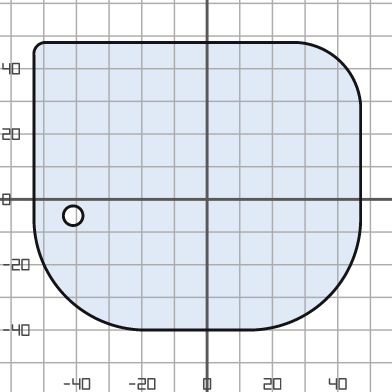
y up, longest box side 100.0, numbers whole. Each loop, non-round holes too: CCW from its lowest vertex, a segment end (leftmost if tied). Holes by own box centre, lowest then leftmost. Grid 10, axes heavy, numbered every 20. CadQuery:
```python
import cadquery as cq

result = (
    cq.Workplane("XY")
    .moveTo(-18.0, -40.0)
    .lineTo(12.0, -40.0)
    .threePointArc((37.0, -30.0), (47.0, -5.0))
    .lineTo(47.0, 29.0)
    .threePointArc((41.0, 42.0), (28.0, 48.0))
    .lineTo(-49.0, 48.0)
    .threePointArc((-52.0, 47.0), (-53.0, 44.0))
    .lineTo(-53.0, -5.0)
    .threePointArc((-43.0, -30.0), (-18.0, -40.0))
    .close()
    .moveTo(-41.0, -5.0)
    .circle(3.0)
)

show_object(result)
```